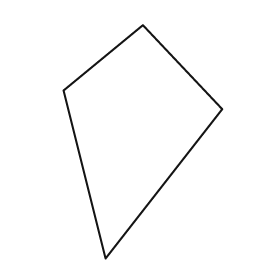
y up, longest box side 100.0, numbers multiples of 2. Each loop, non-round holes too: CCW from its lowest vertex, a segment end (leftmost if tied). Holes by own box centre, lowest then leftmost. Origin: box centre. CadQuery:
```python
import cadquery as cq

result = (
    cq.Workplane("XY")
    .moveTo(-16.0, -50.0)
    .lineTo(34.0, 14.0)
    .lineTo(0.0, 50.0)
    .lineTo(-34.0, 22.0)
    .close()
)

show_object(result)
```